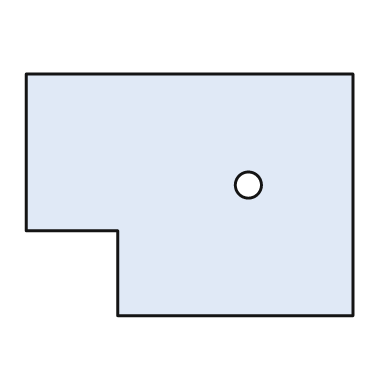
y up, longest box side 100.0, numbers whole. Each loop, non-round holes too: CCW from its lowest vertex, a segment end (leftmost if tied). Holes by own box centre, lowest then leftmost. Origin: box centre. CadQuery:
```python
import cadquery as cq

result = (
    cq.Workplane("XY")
    .moveTo(-22.0, -37.0)
    .lineTo(50.0, -37.0)
    .lineTo(50.0, 37.0)
    .lineTo(-50.0, 37.0)
    .lineTo(-50.0, -11.0)
    .lineTo(-22.0, -11.0)
    .close()
    .moveTo(18.0, 3.0)
    .circle(4.0)
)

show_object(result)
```